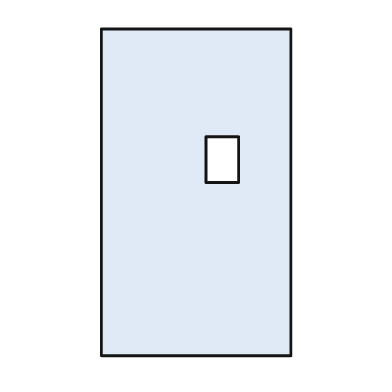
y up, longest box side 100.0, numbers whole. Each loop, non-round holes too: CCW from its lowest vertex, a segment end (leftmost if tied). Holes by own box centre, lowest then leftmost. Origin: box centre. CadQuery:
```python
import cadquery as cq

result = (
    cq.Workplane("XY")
    .moveTo(-29.0, -50.0)
    .lineTo(29.0, -50.0)
    .lineTo(29.0, 50.0)
    .lineTo(-29.0, 50.0)
    .close()
    .moveTo(3.0, 3.0)
    .lineTo(13.0, 3.0)
    .lineTo(13.0, 17.0)
    .lineTo(3.0, 17.0)
    .close()
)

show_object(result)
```